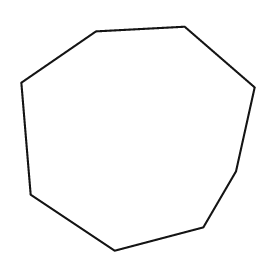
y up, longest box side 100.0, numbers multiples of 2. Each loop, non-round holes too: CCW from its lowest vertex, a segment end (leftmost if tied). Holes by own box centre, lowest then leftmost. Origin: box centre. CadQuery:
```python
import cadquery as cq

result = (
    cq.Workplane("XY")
    .moveTo(-10.0, -48.0)
    .lineTo(28.0, -38.0)
    .lineTo(42.0, -14.0)
    .lineTo(50.0, 22.0)
    .lineTo(20.0, 48.0)
    .lineTo(-18.0, 46.0)
    .lineTo(-50.0, 24.0)
    .lineTo(-46.0, -24.0)
    .close()
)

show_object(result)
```